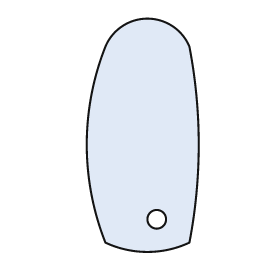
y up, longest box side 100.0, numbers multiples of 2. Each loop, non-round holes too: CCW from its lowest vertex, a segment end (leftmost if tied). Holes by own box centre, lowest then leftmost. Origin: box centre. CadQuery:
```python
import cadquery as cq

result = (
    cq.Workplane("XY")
    .moveTo(-16.0, -46.0)
    .threePointArc((2.0, -50.0), (20.0, -46.0))
    .threePointArc((24.0, -4.0), (20.0, 38.0))
    .threePointArc((2.0, 50.0), (-16.0, 38.0))
    .threePointArc((-24.0, -4.0), (-16.0, -46.0))
    .close()
    .moveTo(6.0, -36.0)
    .circle(4.0)
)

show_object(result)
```